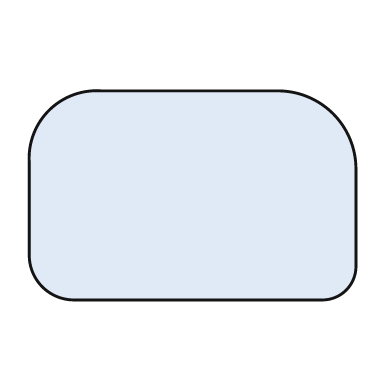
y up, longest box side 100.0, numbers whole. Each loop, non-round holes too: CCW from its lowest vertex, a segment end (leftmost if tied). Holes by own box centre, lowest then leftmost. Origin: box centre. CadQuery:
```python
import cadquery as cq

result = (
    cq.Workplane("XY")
    .moveTo(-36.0, -32.0)
    .lineTo(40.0, -32.0)
    .threePointArc((47.0, -29.0), (50.0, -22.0))
    .lineTo(50.0, 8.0)
    .threePointArc((43.0, 25.0), (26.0, 32.0))
    .lineTo(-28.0, 32.0)
    .threePointArc((-44.0, 26.0), (-50.0, 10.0))
    .lineTo(-50.0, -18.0)
    .threePointArc((-46.0, -28.0), (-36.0, -32.0))
    .close()
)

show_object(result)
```